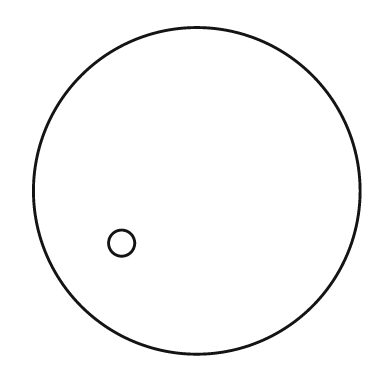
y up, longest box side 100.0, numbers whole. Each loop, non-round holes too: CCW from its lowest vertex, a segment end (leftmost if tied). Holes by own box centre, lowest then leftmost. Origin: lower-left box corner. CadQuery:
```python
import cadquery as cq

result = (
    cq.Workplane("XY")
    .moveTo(50.0, 50.0)
    .circle(50.0)
    .moveTo(27.0, 34.0)
    .circle(4.0)
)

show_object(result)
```